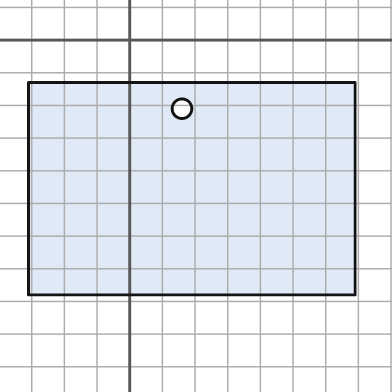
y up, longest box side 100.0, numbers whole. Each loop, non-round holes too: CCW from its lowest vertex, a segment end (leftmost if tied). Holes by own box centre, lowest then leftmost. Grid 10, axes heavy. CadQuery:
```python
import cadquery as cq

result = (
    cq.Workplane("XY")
    .moveTo(-31.0, -78.0)
    .lineTo(69.0, -78.0)
    .lineTo(69.0, -13.0)
    .lineTo(-31.0, -13.0)
    .close()
    .moveTo(16.0, -21.0)
    .circle(3.0)
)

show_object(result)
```